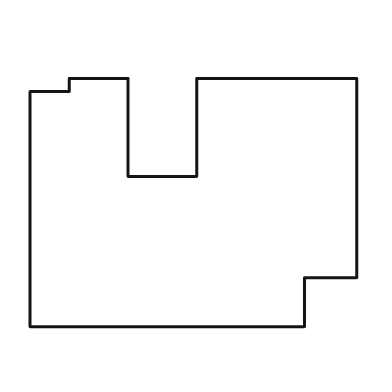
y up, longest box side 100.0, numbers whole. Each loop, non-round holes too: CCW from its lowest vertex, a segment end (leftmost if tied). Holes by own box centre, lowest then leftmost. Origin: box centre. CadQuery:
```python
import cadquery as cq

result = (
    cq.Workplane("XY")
    .moveTo(-50.0, -38.0)
    .lineTo(34.0, -38.0)
    .lineTo(34.0, -23.0)
    .lineTo(50.0, -23.0)
    .lineTo(50.0, 38.0)
    .lineTo(1.0, 38.0)
    .lineTo(1.0, 8.0)
    .lineTo(-20.0, 8.0)
    .lineTo(-20.0, 38.0)
    .lineTo(-38.0, 38.0)
    .lineTo(-38.0, 34.0)
    .lineTo(-50.0, 34.0)
    .close()
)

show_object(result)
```